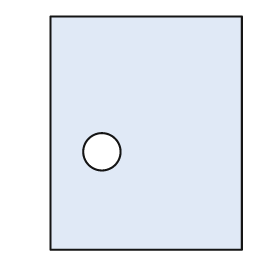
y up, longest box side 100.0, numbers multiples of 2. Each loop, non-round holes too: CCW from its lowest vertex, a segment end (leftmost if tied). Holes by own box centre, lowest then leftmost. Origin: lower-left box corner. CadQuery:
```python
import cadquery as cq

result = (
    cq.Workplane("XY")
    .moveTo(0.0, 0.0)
    .lineTo(82.0, 0.0)
    .lineTo(82.0, 100.0)
    .lineTo(0.0, 100.0)
    .close()
    .moveTo(22.0, 42.0)
    .circle(8.0)
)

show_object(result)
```